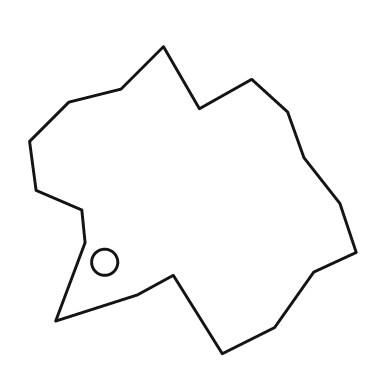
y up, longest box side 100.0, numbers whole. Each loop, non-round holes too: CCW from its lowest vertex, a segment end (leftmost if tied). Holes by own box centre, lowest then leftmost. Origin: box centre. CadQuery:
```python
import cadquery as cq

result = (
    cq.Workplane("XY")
    .moveTo(9.0, -47.0)
    .lineTo(25.0, -39.0)
    .lineTo(37.0, -22.0)
    .lineTo(50.0, -16.0)
    .lineTo(45.0, -1.0)
    .lineTo(34.0, 13.0)
    .lineTo(29.0, 27.0)
    .lineTo(18.0, 37.0)
    .lineTo(2.0, 28.0)
    .lineTo(-9.0, 47.0)
    .lineTo(-22.0, 34.0)
    .lineTo(-38.0, 30.0)
    .lineTo(-50.0, 18.0)
    .lineTo(-48.0, 3.0)
    .lineTo(-34.0, -3.0)
    .lineTo(-33.0, -13.0)
    .lineTo(-42.0, -37.0)
    .lineTo(-17.0, -29.0)
    .lineTo(-6.0, -23.0)
    .close()
    .moveTo(-27.0, -19.0)
    .circle(4.0)
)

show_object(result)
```